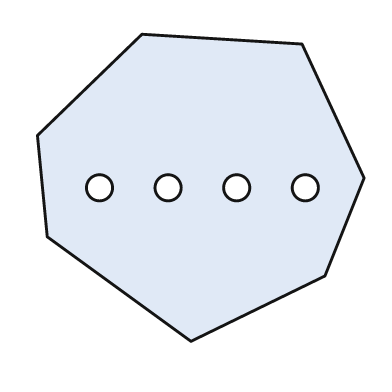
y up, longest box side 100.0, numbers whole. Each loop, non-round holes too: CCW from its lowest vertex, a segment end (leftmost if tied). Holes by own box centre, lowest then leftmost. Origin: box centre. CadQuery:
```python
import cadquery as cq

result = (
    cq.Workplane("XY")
    .moveTo(-3.0, -47.0)
    .lineTo(38.0, -27.0)
    .lineTo(50.0, 3.0)
    .lineTo(31.0, 44.0)
    .lineTo(-18.0, 47.0)
    .lineTo(-50.0, 16.0)
    .lineTo(-47.0, -15.0)
    .close()
    .moveTo(-31.0, 0.0)
    .circle(4.0)
    .moveTo(-10.0, 0.0)
    .circle(4.0)
    .moveTo(11.0, 0.0)
    .circle(4.0)
    .moveTo(32.0, 0.0)
    .circle(4.0)
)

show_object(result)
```